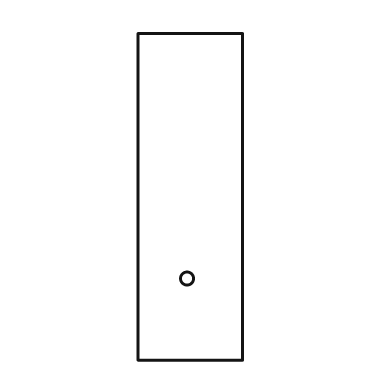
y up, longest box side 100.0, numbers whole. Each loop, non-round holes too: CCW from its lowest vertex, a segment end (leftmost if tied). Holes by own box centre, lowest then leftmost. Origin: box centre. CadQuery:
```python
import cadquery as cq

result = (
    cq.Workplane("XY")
    .moveTo(-16.0, -50.0)
    .lineTo(16.0, -50.0)
    .lineTo(16.0, 50.0)
    .lineTo(-16.0, 50.0)
    .close()
    .moveTo(-1.0, -25.0)
    .circle(2.0)
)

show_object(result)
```